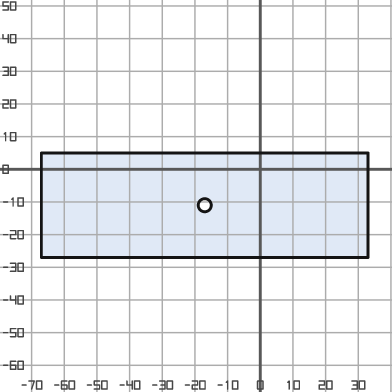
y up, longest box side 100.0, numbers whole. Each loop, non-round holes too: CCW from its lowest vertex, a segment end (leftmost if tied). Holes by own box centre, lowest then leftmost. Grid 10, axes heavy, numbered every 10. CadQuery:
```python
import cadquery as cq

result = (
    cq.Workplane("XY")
    .moveTo(-67.0, -27.0)
    .lineTo(33.0, -27.0)
    .lineTo(33.0, 5.0)
    .lineTo(-67.0, 5.0)
    .close()
    .moveTo(-17.0, -11.0)
    .circle(2.0)
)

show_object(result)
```